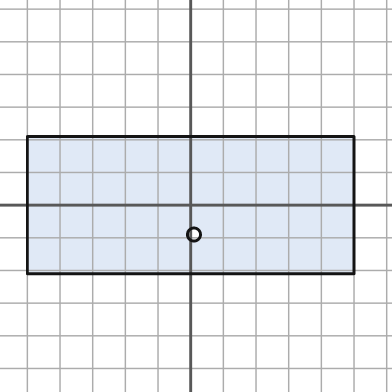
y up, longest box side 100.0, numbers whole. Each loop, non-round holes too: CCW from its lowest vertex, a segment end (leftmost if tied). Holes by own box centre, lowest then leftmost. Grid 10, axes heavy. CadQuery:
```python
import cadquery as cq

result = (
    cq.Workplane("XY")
    .moveTo(-50.0, -21.0)
    .lineTo(50.0, -21.0)
    .lineTo(50.0, 21.0)
    .lineTo(-50.0, 21.0)
    .close()
    .moveTo(1.0, -9.0)
    .circle(2.0)
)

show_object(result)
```